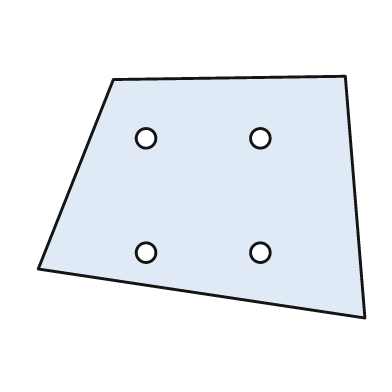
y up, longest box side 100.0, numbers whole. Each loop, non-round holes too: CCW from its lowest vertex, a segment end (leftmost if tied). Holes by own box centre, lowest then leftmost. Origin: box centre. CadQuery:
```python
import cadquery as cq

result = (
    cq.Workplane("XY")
    .moveTo(50.0, -37.0)
    .lineTo(44.0, 37.0)
    .lineTo(-27.0, 36.0)
    .lineTo(-50.0, -22.0)
    .close()
    .moveTo(-17.0, -17.0)
    .circle(3.0)
    .moveTo(18.0, -17.0)
    .circle(3.0)
    .moveTo(-17.0, 18.0)
    .circle(3.0)
    .moveTo(18.0, 18.0)
    .circle(3.0)
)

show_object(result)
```